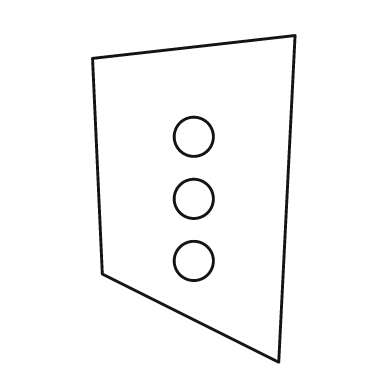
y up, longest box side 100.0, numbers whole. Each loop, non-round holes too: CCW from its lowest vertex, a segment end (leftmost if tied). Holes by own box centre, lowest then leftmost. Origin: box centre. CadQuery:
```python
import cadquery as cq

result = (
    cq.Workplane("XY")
    .moveTo(26.0, -50.0)
    .lineTo(31.0, 50.0)
    .lineTo(-31.0, 43.0)
    .lineTo(-28.0, -23.0)
    .close()
    .moveTo(0.0, -19.0)
    .circle(6.0)
    .moveTo(0.0, 0.0)
    .circle(6.0)
    .moveTo(0.0, 19.0)
    .circle(6.0)
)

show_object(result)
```